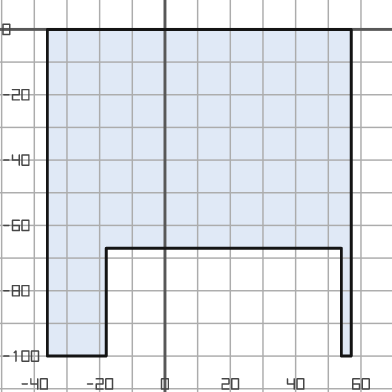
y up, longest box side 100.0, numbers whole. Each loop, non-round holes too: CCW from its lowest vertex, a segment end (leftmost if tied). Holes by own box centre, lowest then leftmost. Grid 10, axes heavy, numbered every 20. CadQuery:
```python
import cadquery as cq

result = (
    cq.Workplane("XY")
    .moveTo(-36.0, -100.0)
    .lineTo(-18.0, -100.0)
    .lineTo(-18.0, -67.0)
    .lineTo(54.0, -67.0)
    .lineTo(54.0, -100.0)
    .lineTo(57.0, -100.0)
    .lineTo(57.0, 0.0)
    .lineTo(-36.0, 0.0)
    .close()
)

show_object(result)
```